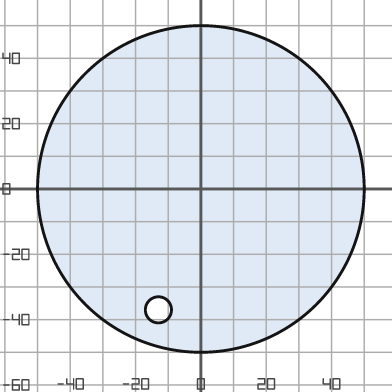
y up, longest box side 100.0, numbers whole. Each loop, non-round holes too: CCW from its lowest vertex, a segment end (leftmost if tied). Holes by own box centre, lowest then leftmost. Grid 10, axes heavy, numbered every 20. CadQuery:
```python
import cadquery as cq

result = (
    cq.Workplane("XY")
    .moveTo(0.0, 0.0)
    .circle(50.0)
    .moveTo(-13.0, -37.0)
    .circle(4.0)
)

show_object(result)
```